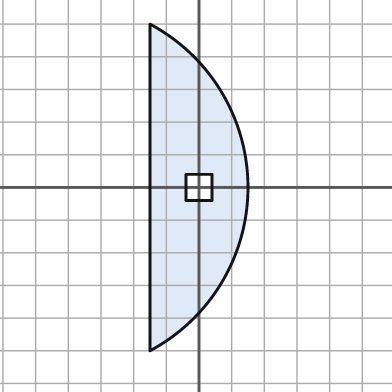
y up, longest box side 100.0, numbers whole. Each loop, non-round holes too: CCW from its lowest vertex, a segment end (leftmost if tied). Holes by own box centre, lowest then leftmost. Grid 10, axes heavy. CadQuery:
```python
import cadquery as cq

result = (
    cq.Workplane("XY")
    .moveTo(-15.0, -50.0)
    .threePointArc((15.0, 0.0), (-15.0, 50.0))
    .close()
    .moveTo(-4.0, -4.0)
    .lineTo(4.0, -4.0)
    .lineTo(4.0, 4.0)
    .lineTo(-4.0, 4.0)
    .close()
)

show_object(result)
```